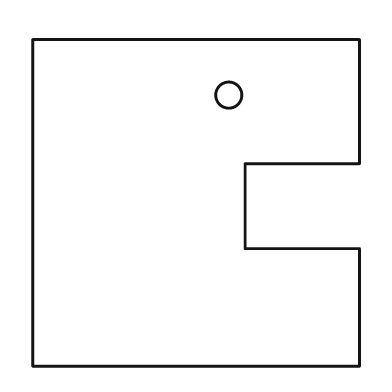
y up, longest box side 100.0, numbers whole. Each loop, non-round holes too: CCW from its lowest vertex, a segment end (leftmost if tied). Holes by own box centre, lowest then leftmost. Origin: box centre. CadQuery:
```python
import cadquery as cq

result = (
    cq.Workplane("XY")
    .moveTo(-50.0, -50.0)
    .lineTo(50.0, -50.0)
    .lineTo(50.0, -14.0)
    .lineTo(15.0, -14.0)
    .lineTo(15.0, 12.0)
    .lineTo(50.0, 12.0)
    .lineTo(50.0, 50.0)
    .lineTo(-50.0, 50.0)
    .close()
    .moveTo(10.0, 33.0)
    .circle(4.0)
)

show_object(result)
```